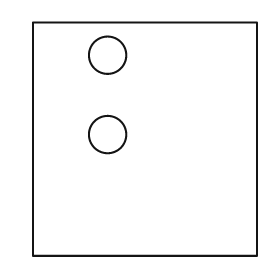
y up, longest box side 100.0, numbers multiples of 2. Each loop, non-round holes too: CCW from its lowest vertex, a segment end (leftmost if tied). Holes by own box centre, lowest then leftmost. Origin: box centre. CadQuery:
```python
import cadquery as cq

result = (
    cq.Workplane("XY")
    .moveTo(-48.0, -50.0)
    .lineTo(48.0, -50.0)
    .lineTo(48.0, 50.0)
    .lineTo(-48.0, 50.0)
    .close()
    .moveTo(-16.0, 2.0)
    .circle(8.0)
    .moveTo(-16.0, 36.0)
    .circle(8.0)
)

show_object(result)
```